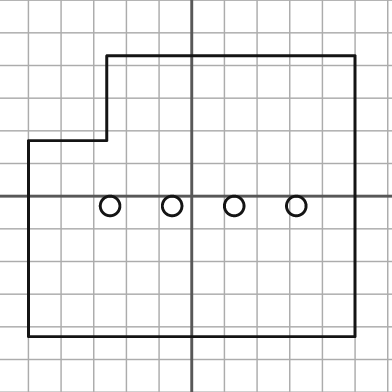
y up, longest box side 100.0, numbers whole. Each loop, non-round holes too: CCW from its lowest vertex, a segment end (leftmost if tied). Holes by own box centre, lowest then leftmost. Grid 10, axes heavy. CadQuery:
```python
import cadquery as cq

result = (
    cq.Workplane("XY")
    .moveTo(-50.0, -43.0)
    .lineTo(50.0, -43.0)
    .lineTo(50.0, 43.0)
    .lineTo(-26.0, 43.0)
    .lineTo(-26.0, 17.0)
    .lineTo(-50.0, 17.0)
    .close()
    .moveTo(-25.0, -3.0)
    .circle(3.0)
    .moveTo(-6.0, -3.0)
    .circle(3.0)
    .moveTo(13.0, -3.0)
    .circle(3.0)
    .moveTo(32.0, -3.0)
    .circle(3.0)
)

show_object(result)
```